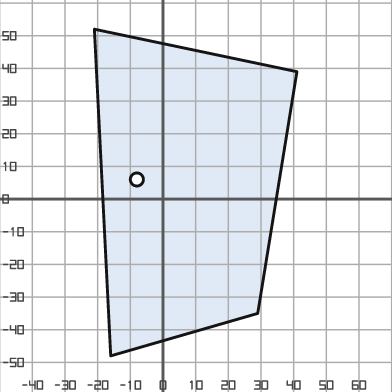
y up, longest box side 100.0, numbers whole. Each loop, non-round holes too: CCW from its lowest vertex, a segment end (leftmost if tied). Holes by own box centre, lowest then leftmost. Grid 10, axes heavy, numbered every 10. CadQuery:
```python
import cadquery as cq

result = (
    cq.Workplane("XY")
    .moveTo(-16.0, -48.0)
    .lineTo(29.0, -35.0)
    .lineTo(41.0, 39.0)
    .lineTo(-21.0, 52.0)
    .close()
    .moveTo(-8.0, 6.0)
    .circle(2.0)
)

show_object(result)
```